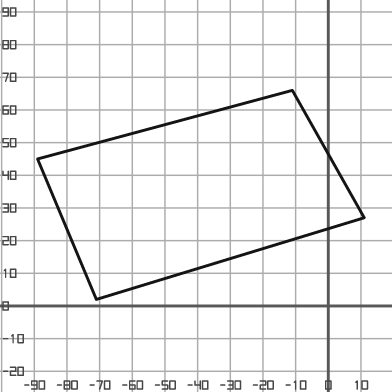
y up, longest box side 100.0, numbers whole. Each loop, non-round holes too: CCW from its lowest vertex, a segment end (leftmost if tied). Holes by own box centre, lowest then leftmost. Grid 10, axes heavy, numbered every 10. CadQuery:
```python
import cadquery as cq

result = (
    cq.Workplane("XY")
    .moveTo(-71.0, 2.0)
    .lineTo(11.0, 27.0)
    .lineTo(-11.0, 66.0)
    .lineTo(-89.0, 45.0)
    .close()
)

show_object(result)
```